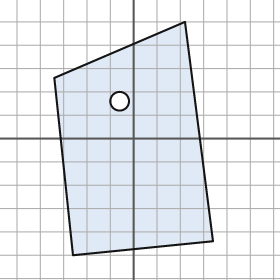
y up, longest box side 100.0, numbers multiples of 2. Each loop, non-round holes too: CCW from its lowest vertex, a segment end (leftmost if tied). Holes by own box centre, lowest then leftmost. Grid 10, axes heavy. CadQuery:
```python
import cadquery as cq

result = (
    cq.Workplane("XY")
    .moveTo(-26.0, -50.0)
    .lineTo(34.0, -44.0)
    .lineTo(22.0, 50.0)
    .lineTo(-34.0, 26.0)
    .close()
    .moveTo(-6.0, 16.0)
    .circle(4.0)
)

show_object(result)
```